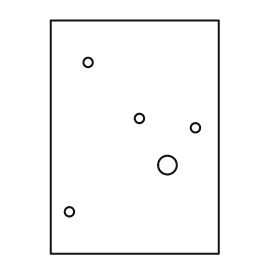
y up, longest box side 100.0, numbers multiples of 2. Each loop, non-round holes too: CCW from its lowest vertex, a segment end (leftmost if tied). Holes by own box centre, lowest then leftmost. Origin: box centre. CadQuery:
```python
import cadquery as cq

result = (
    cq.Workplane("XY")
    .moveTo(-36.0, -50.0)
    .lineTo(36.0, -50.0)
    .lineTo(36.0, 50.0)
    .lineTo(-36.0, 50.0)
    .close()
    .moveTo(-28.0, -32.0)
    .circle(2.0)
    .moveTo(14.0, -12.0)
    .circle(4.0)
    .moveTo(26.0, 4.0)
    .circle(2.0)
    .moveTo(2.0, 8.0)
    .circle(2.0)
    .moveTo(-20.0, 32.0)
    .circle(2.0)
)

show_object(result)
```